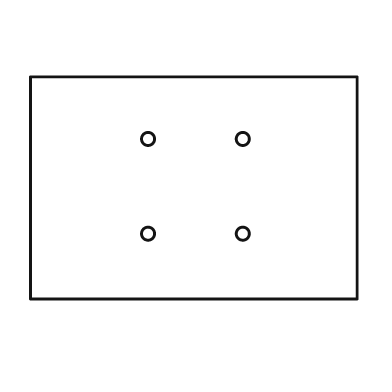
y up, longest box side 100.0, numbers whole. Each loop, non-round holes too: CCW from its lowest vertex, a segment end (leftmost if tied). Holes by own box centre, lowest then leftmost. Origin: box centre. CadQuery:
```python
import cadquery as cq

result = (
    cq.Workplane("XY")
    .moveTo(-50.0, -34.0)
    .lineTo(50.0, -34.0)
    .lineTo(50.0, 34.0)
    .lineTo(-50.0, 34.0)
    .close()
    .moveTo(-14.0, -14.0)
    .circle(2.0)
    .moveTo(15.0, -14.0)
    .circle(2.0)
    .moveTo(-14.0, 15.0)
    .circle(2.0)
    .moveTo(15.0, 15.0)
    .circle(2.0)
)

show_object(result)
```